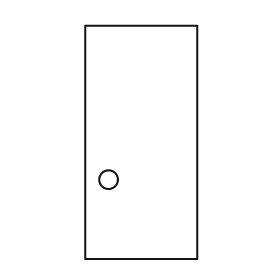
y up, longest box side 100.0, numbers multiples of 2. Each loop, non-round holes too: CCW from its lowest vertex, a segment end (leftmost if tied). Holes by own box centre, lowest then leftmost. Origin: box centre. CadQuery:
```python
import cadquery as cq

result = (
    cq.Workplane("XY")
    .moveTo(-24.0, -50.0)
    .lineTo(24.0, -50.0)
    .lineTo(24.0, 50.0)
    .lineTo(-24.0, 50.0)
    .close()
    .moveTo(-14.0, -16.0)
    .circle(4.0)
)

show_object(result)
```